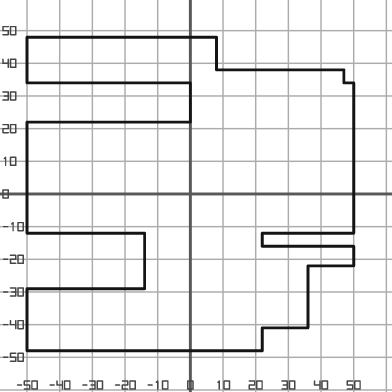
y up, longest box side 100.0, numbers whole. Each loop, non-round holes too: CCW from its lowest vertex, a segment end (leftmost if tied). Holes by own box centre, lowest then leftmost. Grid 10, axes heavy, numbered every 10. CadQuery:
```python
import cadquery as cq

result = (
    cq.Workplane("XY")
    .moveTo(-50.0, -48.0)
    .lineTo(22.0, -48.0)
    .lineTo(22.0, -41.0)
    .lineTo(36.0, -41.0)
    .lineTo(36.0, -22.0)
    .lineTo(50.0, -22.0)
    .lineTo(50.0, -16.0)
    .lineTo(22.0, -16.0)
    .lineTo(22.0, -12.0)
    .lineTo(50.0, -12.0)
    .lineTo(50.0, 34.0)
    .lineTo(47.0, 34.0)
    .lineTo(47.0, 38.0)
    .lineTo(8.0, 38.0)
    .lineTo(8.0, 48.0)
    .lineTo(-50.0, 48.0)
    .lineTo(-50.0, 34.0)
    .lineTo(0.0, 34.0)
    .lineTo(0.0, 22.0)
    .lineTo(-50.0, 22.0)
    .lineTo(-50.0, -12.0)
    .lineTo(-14.0, -12.0)
    .lineTo(-14.0, -29.0)
    .lineTo(-50.0, -29.0)
    .close()
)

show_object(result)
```